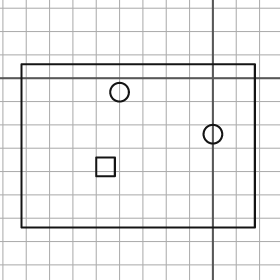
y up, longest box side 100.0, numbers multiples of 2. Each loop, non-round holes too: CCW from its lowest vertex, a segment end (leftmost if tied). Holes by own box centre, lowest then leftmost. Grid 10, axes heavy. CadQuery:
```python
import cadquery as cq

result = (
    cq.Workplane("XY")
    .moveTo(-82.0, -64.0)
    .lineTo(18.0, -64.0)
    .lineTo(18.0, 6.0)
    .lineTo(-82.0, 6.0)
    .close()
    .moveTo(-50.0, -42.0)
    .lineTo(-42.0, -42.0)
    .lineTo(-42.0, -34.0)
    .lineTo(-50.0, -34.0)
    .close()
    .moveTo(0.0, -24.0)
    .circle(4.0)
    .moveTo(-40.0, -6.0)
    .circle(4.0)
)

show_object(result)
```